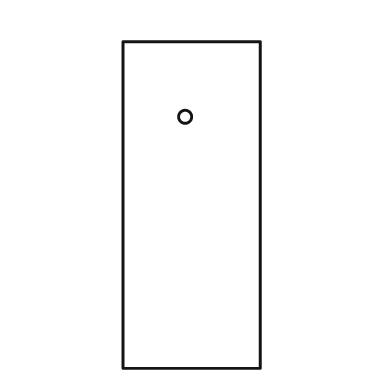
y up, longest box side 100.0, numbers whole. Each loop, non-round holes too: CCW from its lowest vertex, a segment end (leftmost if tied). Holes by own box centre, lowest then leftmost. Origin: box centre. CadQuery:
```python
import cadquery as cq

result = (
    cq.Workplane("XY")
    .moveTo(-21.0, -50.0)
    .lineTo(21.0, -50.0)
    .lineTo(21.0, 50.0)
    .lineTo(-21.0, 50.0)
    .close()
    .moveTo(-2.0, 27.0)
    .circle(2.0)
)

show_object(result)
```